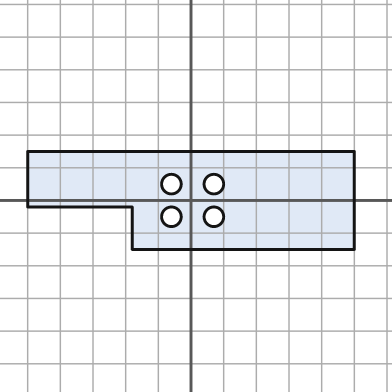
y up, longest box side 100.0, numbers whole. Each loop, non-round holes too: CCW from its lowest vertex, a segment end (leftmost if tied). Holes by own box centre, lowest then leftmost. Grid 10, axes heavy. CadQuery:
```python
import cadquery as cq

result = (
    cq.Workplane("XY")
    .moveTo(-18.0, -15.0)
    .lineTo(50.0, -15.0)
    .lineTo(50.0, 15.0)
    .lineTo(-50.0, 15.0)
    .lineTo(-50.0, -2.0)
    .lineTo(-18.0, -2.0)
    .close()
    .moveTo(-6.0, -5.0)
    .circle(3.0)
    .moveTo(7.0, -5.0)
    .circle(3.0)
    .moveTo(-6.0, 5.0)
    .circle(3.0)
    .moveTo(7.0, 5.0)
    .circle(3.0)
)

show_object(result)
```